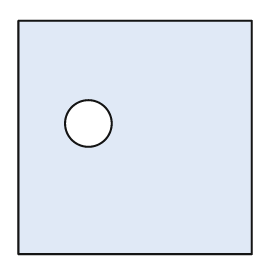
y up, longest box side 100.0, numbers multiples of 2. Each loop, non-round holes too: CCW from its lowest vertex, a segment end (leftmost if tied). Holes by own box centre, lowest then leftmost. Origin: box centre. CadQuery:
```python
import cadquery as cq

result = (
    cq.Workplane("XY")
    .moveTo(-50.0, -50.0)
    .lineTo(50.0, -50.0)
    .lineTo(50.0, 50.0)
    .lineTo(-50.0, 50.0)
    .close()
    .moveTo(-20.0, 6.0)
    .circle(10.0)
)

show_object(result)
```